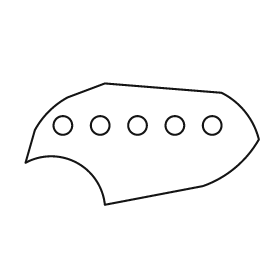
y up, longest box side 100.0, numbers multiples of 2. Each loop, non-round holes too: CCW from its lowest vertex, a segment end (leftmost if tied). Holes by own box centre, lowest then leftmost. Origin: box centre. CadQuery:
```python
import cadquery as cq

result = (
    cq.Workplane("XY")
    .moveTo(-16.0, -26.0)
    .lineTo(26.0, -18.0)
    .threePointArc((40.0, -10.0), (50.0, 2.0))
    .threePointArc((44.0, 14.0), (34.0, 22.0))
    .lineTo(-16.0, 26.0)
    .lineTo(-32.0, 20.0)
    .threePointArc((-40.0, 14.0), (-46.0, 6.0))
    .lineTo(-50.0, -8.0)
    .threePointArc((-28.0, -8.0), (-16.0, -26.0))
    .close()
    .moveTo(-34.0, 8.0)
    .circle(4.0)
    .moveTo(-18.0, 8.0)
    .circle(4.0)
    .moveTo(-2.0, 8.0)
    .circle(4.0)
    .moveTo(14.0, 8.0)
    .circle(4.0)
    .moveTo(30.0, 8.0)
    .circle(4.0)
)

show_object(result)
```